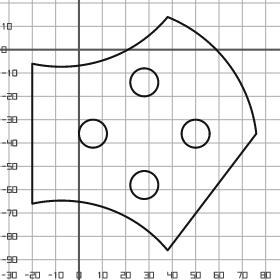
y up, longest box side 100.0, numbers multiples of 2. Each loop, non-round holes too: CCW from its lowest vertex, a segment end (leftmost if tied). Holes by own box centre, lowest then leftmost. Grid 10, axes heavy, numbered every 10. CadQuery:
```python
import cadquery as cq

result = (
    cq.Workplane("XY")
    .moveTo(38.0, -86.0)
    .lineTo(76.0, -36.0)
    .threePointArc((64.0, -6.0), (38.0, 14.0))
    .threePointArc((12.0, -4.0), (-20.0, -6.0))
    .lineTo(-20.0, -66.0)
    .threePointArc((12.0, -68.0), (38.0, -86.0))
    .close()
    .moveTo(28.0, -58.0)
    .circle(6.0)
    .moveTo(6.0, -36.0)
    .circle(6.0)
    .moveTo(50.0, -36.0)
    .circle(6.0)
    .moveTo(28.0, -14.0)
    .circle(6.0)
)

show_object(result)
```